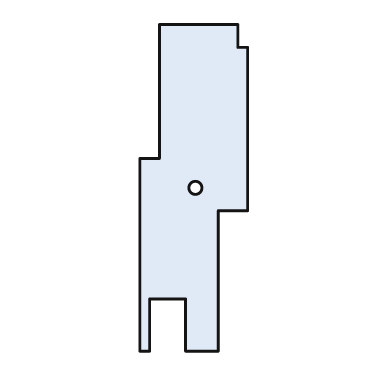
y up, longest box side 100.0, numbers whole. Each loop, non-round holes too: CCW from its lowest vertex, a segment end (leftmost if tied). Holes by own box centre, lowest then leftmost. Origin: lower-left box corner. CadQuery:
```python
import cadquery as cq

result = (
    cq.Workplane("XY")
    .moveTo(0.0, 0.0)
    .lineTo(3.0, 0.0)
    .lineTo(3.0, 16.0)
    .lineTo(14.0, 16.0)
    .lineTo(14.0, 0.0)
    .lineTo(24.0, 0.0)
    .lineTo(24.0, 43.0)
    .lineTo(33.0, 43.0)
    .lineTo(33.0, 93.0)
    .lineTo(30.0, 93.0)
    .lineTo(30.0, 100.0)
    .lineTo(6.0, 100.0)
    .lineTo(6.0, 59.0)
    .lineTo(0.0, 59.0)
    .close()
    .moveTo(17.0, 50.0)
    .circle(2.0)
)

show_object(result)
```